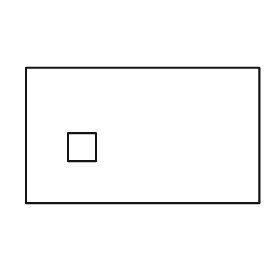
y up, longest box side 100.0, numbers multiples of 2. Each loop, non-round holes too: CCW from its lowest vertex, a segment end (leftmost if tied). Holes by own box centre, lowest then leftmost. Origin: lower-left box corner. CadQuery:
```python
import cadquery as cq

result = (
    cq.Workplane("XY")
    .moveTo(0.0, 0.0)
    .lineTo(100.0, 0.0)
    .lineTo(100.0, 58.0)
    .lineTo(0.0, 58.0)
    .close()
    .moveTo(18.0, 18.0)
    .lineTo(30.0, 18.0)
    .lineTo(30.0, 30.0)
    .lineTo(18.0, 30.0)
    .close()
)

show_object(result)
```